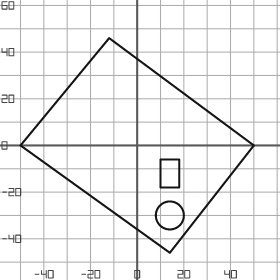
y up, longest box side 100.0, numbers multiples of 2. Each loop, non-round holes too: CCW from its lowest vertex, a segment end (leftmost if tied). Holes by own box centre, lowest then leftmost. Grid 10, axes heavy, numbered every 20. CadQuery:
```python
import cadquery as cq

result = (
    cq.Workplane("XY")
    .moveTo(14.0, -46.0)
    .lineTo(50.0, 0.0)
    .lineTo(-12.0, 46.0)
    .lineTo(-50.0, 0.0)
    .close()
    .moveTo(14.0, -30.0)
    .circle(6.0)
    .moveTo(10.0, -18.0)
    .lineTo(18.0, -18.0)
    .lineTo(18.0, -6.0)
    .lineTo(10.0, -6.0)
    .close()
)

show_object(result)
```